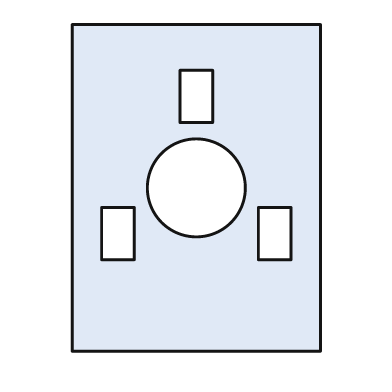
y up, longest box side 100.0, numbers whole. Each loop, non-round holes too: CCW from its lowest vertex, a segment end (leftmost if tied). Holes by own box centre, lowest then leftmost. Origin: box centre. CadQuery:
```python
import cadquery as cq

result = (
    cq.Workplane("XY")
    .moveTo(-38.0, -50.0)
    .lineTo(38.0, -50.0)
    .lineTo(38.0, 50.0)
    .lineTo(-38.0, 50.0)
    .close()
    .moveTo(-29.0, -22.0)
    .lineTo(-19.0, -22.0)
    .lineTo(-19.0, -6.0)
    .lineTo(-29.0, -6.0)
    .close()
    .moveTo(19.0, -22.0)
    .lineTo(29.0, -22.0)
    .lineTo(29.0, -6.0)
    .lineTo(19.0, -6.0)
    .close()
    .moveTo(0.0, 0.0)
    .circle(15.0)
    .moveTo(-5.0, 20.0)
    .lineTo(5.0, 20.0)
    .lineTo(5.0, 36.0)
    .lineTo(-5.0, 36.0)
    .close()
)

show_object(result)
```